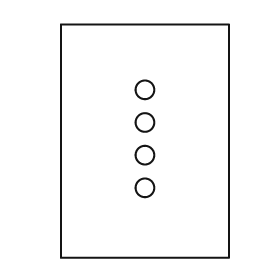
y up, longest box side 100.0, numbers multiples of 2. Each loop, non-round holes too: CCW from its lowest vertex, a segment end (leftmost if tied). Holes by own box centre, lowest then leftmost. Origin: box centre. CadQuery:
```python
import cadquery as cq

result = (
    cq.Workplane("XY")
    .moveTo(-36.0, -50.0)
    .lineTo(36.0, -50.0)
    .lineTo(36.0, 50.0)
    .lineTo(-36.0, 50.0)
    .close()
    .moveTo(0.0, -20.0)
    .circle(4.0)
    .moveTo(0.0, -6.0)
    .circle(4.0)
    .moveTo(0.0, 8.0)
    .circle(4.0)
    .moveTo(0.0, 22.0)
    .circle(4.0)
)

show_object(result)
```